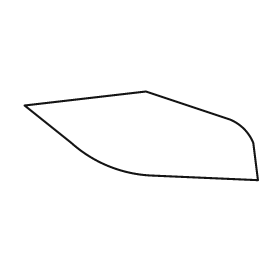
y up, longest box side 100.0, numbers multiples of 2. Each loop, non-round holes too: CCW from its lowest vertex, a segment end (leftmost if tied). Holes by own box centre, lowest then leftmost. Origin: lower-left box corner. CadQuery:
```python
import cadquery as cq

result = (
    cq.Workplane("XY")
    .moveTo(100.0, 0.0)
    .lineTo(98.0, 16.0)
    .threePointArc((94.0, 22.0), (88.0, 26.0))
    .lineTo(52.0, 38.0)
    .lineTo(0.0, 32.0)
    .lineTo(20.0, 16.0)
    .threePointArc((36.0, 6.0), (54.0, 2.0))
    .close()
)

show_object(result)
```